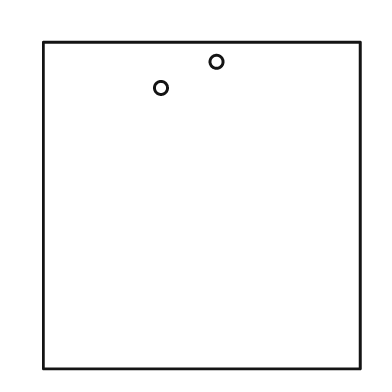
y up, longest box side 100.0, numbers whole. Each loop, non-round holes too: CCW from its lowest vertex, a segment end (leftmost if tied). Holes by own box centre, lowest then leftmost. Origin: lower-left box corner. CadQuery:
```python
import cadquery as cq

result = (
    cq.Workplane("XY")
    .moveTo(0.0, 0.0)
    .lineTo(97.0, 0.0)
    .lineTo(97.0, 100.0)
    .lineTo(0.0, 100.0)
    .close()
    .moveTo(36.0, 86.0)
    .circle(2.0)
    .moveTo(53.0, 94.0)
    .circle(2.0)
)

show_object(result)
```